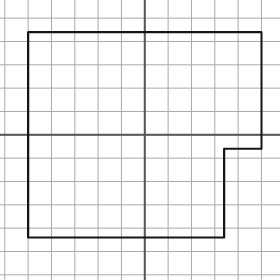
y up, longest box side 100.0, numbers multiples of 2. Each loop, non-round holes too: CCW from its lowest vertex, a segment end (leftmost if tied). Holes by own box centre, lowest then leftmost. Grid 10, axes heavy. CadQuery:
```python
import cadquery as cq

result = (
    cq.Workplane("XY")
    .moveTo(-50.0, -44.0)
    .lineTo(34.0, -44.0)
    .lineTo(34.0, -6.0)
    .lineTo(50.0, -6.0)
    .lineTo(50.0, 44.0)
    .lineTo(-50.0, 44.0)
    .close()
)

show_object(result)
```